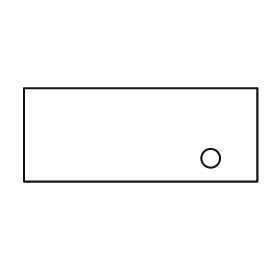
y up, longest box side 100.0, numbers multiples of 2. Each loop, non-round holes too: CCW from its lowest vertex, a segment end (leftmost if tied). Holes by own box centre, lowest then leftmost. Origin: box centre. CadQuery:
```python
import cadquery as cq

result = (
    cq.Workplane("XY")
    .moveTo(-50.0, -20.0)
    .lineTo(50.0, -20.0)
    .lineTo(50.0, 20.0)
    .lineTo(-50.0, 20.0)
    .close()
    .moveTo(30.0, -10.0)
    .circle(4.0)
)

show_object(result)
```